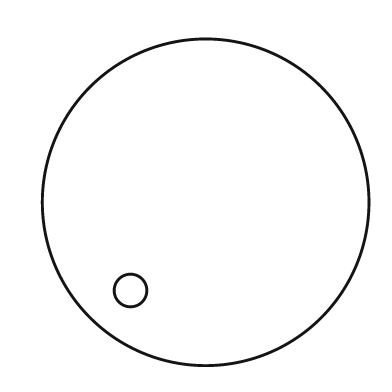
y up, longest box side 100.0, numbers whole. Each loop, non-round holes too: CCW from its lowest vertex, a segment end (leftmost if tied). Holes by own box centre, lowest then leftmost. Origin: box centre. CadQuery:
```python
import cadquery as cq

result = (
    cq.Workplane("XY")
    .moveTo(0.0, 0.0)
    .circle(50.0)
    .moveTo(-23.0, -27.0)
    .circle(5.0)
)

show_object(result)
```